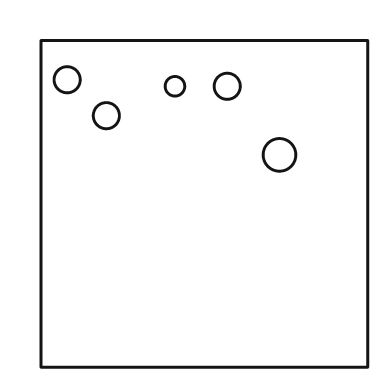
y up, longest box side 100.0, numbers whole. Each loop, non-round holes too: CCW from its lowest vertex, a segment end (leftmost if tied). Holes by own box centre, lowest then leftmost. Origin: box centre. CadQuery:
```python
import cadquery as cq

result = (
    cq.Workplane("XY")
    .moveTo(-50.0, -50.0)
    .lineTo(50.0, -50.0)
    .lineTo(50.0, 50.0)
    .lineTo(-50.0, 50.0)
    .close()
    .moveTo(23.0, 15.0)
    .circle(5.0)
    .moveTo(-30.0, 27.0)
    .circle(4.0)
    .moveTo(-9.0, 36.0)
    .circle(3.0)
    .moveTo(7.0, 36.0)
    .circle(4.0)
    .moveTo(-42.0, 38.0)
    .circle(4.0)
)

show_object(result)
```